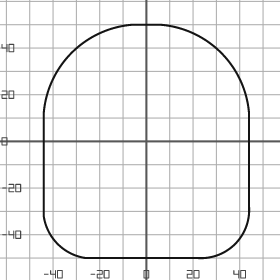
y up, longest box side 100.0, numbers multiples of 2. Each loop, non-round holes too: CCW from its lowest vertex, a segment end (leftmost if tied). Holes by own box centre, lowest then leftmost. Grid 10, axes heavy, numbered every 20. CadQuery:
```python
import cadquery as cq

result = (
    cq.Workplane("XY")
    .moveTo(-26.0, -50.0)
    .lineTo(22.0, -50.0)
    .threePointArc((38.0, -44.0), (44.0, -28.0))
    .lineTo(44.0, 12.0)
    .threePointArc((32.0, 38.0), (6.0, 50.0))
    .lineTo(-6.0, 50.0)
    .threePointArc((-32.0, 38.0), (-44.0, 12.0))
    .lineTo(-44.0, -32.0)
    .threePointArc((-38.0, -44.0), (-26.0, -50.0))
    .close()
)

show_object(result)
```